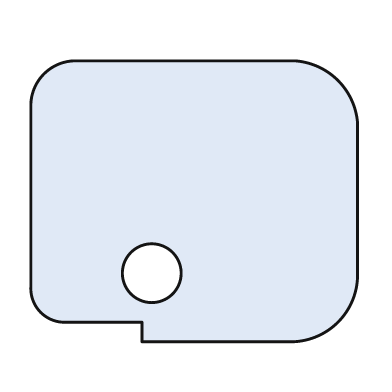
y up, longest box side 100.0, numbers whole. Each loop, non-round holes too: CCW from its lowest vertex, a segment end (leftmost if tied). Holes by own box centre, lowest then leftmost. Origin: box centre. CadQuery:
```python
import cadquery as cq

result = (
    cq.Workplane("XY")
    .moveTo(-16.0, -43.0)
    .lineTo(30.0, -43.0)
    .threePointArc((44.0, -37.0), (50.0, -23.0))
    .lineTo(50.0, 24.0)
    .threePointArc((44.0, 37.0), (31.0, 43.0))
    .lineTo(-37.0, 43.0)
    .threePointArc((-46.0, 39.0), (-50.0, 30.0))
    .lineTo(-50.0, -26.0)
    .threePointArc((-47.0, -34.0), (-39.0, -37.0))
    .lineTo(-16.0, -37.0)
    .close()
    .moveTo(-13.0, -22.0)
    .circle(9.0)
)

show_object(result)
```